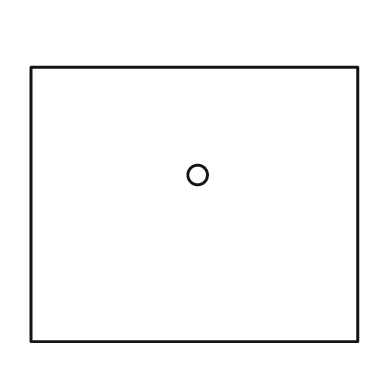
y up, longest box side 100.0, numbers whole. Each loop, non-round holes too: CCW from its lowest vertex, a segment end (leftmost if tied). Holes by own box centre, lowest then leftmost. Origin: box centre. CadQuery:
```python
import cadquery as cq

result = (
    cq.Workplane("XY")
    .moveTo(-50.0, -42.0)
    .lineTo(50.0, -42.0)
    .lineTo(50.0, 42.0)
    .lineTo(-50.0, 42.0)
    .close()
    .moveTo(1.0, 9.0)
    .circle(3.0)
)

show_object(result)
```